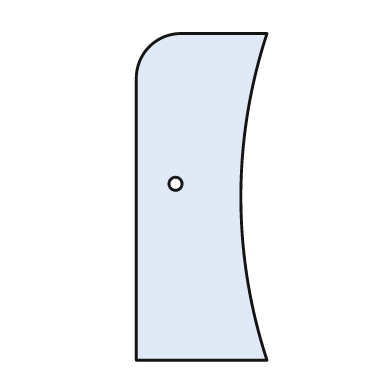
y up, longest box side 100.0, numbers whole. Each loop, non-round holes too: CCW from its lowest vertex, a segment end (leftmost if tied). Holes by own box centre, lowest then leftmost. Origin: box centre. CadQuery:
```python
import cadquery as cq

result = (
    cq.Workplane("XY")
    .moveTo(-20.0, -50.0)
    .lineTo(20.0, -50.0)
    .threePointArc((12.0, 0.0), (20.0, 50.0))
    .lineTo(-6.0, 50.0)
    .threePointArc((-16.0, 46.0), (-20.0, 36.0))
    .close()
    .moveTo(-8.0, 4.0)
    .circle(2.0)
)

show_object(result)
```